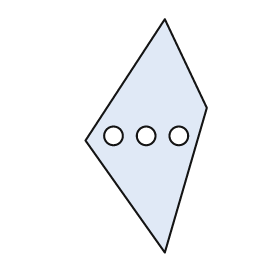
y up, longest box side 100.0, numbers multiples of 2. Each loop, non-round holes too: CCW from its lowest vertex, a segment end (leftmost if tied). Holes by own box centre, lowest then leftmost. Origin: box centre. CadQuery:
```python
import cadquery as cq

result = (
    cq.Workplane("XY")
    .moveTo(8.0, -50.0)
    .lineTo(26.0, 12.0)
    .lineTo(8.0, 50.0)
    .lineTo(-26.0, -2.0)
    .close()
    .moveTo(-14.0, 0.0)
    .circle(4.0)
    .moveTo(0.0, 0.0)
    .circle(4.0)
    .moveTo(14.0, 0.0)
    .circle(4.0)
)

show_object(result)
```